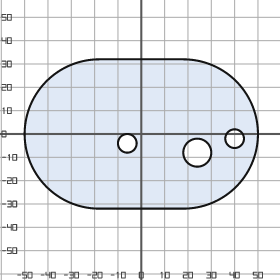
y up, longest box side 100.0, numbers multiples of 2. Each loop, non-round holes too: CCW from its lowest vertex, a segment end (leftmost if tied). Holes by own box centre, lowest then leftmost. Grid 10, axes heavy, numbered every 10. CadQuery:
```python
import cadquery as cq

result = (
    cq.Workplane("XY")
    .moveTo(-18.0, -32.0)
    .lineTo(18.0, -32.0)
    .threePointArc((50.0, 0.0), (18.0, 32.0))
    .lineTo(-18.0, 32.0)
    .threePointArc((-50.0, 0.0), (-18.0, -32.0))
    .close()
    .moveTo(24.0, -8.0)
    .circle(6.0)
    .moveTo(-6.0, -4.0)
    .circle(4.0)
    .moveTo(40.0, -2.0)
    .circle(4.0)
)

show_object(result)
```